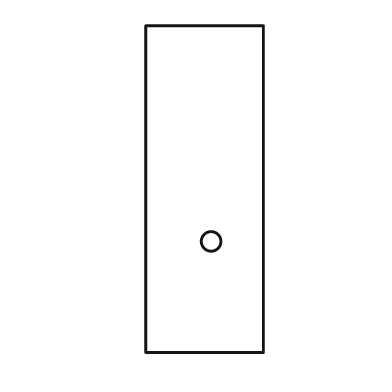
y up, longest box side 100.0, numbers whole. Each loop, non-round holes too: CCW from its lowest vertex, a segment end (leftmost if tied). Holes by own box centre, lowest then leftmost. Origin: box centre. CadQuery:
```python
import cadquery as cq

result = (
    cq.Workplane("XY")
    .moveTo(-18.0, -50.0)
    .lineTo(18.0, -50.0)
    .lineTo(18.0, 50.0)
    .lineTo(-18.0, 50.0)
    .close()
    .moveTo(2.0, -16.0)
    .circle(3.0)
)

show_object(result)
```